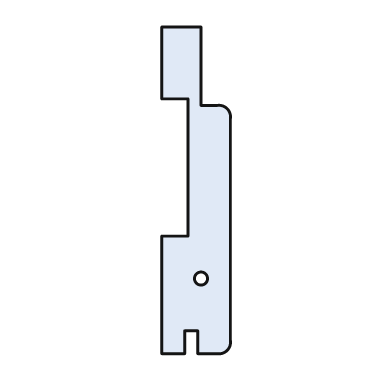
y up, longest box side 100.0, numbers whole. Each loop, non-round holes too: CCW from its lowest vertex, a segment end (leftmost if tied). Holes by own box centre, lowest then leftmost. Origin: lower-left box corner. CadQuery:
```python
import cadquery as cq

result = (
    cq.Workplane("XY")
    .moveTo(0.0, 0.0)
    .lineTo(7.0, 0.0)
    .lineTo(7.0, 7.0)
    .lineTo(11.0, 7.0)
    .lineTo(11.0, 0.0)
    .lineTo(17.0, 0.0)
    .threePointArc((20.0, 1.0), (21.0, 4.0))
    .lineTo(21.0, 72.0)
    .threePointArc((20.0, 75.0), (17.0, 76.0))
    .lineTo(12.0, 76.0)
    .lineTo(12.0, 100.0)
    .lineTo(0.0, 100.0)
    .lineTo(0.0, 78.0)
    .lineTo(8.0, 78.0)
    .lineTo(8.0, 36.0)
    .lineTo(0.0, 36.0)
    .close()
    .moveTo(12.0, 23.0)
    .circle(2.0)
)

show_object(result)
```